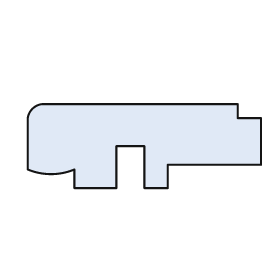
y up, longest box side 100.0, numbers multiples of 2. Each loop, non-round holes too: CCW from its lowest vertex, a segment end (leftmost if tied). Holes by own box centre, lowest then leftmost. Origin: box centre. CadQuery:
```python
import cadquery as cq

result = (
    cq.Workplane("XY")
    .moveTo(-30.0, -18.0)
    .lineTo(-12.0, -18.0)
    .lineTo(-12.0, 0.0)
    .lineTo(0.0, 0.0)
    .lineTo(0.0, -18.0)
    .lineTo(10.0, -18.0)
    .lineTo(10.0, -8.0)
    .lineTo(50.0, -8.0)
    .lineTo(50.0, 12.0)
    .lineTo(40.0, 12.0)
    .lineTo(40.0, 18.0)
    .lineTo(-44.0, 18.0)
    .threePointArc((-48.0, 16.0), (-50.0, 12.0))
    .lineTo(-50.0, -10.0)
    .threePointArc((-40.0, -12.0), (-30.0, -10.0))
    .close()
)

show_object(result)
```